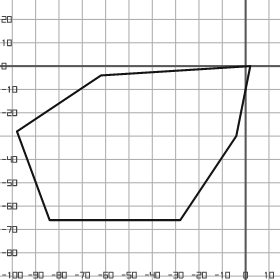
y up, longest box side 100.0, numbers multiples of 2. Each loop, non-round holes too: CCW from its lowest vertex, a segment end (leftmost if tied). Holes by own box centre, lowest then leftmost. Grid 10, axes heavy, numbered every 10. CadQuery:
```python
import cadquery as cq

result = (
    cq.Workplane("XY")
    .moveTo(-84.0, -66.0)
    .lineTo(-28.0, -66.0)
    .lineTo(-4.0, -30.0)
    .lineTo(2.0, 0.0)
    .lineTo(-62.0, -4.0)
    .lineTo(-98.0, -28.0)
    .close()
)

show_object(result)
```